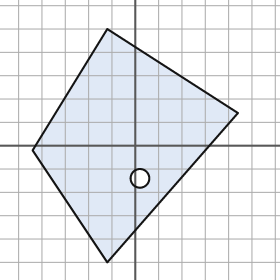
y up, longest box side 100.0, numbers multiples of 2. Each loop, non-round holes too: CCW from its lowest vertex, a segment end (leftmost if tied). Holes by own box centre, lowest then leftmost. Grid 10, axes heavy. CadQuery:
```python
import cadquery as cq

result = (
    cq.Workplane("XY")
    .moveTo(-12.0, -50.0)
    .lineTo(44.0, 14.0)
    .lineTo(-12.0, 50.0)
    .lineTo(-44.0, -2.0)
    .close()
    .moveTo(2.0, -14.0)
    .circle(4.0)
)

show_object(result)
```